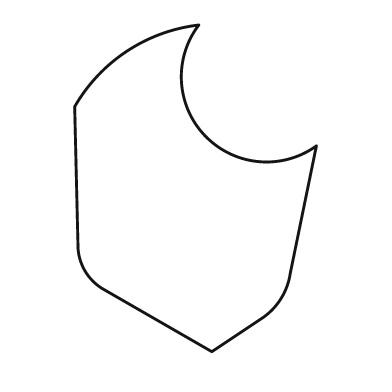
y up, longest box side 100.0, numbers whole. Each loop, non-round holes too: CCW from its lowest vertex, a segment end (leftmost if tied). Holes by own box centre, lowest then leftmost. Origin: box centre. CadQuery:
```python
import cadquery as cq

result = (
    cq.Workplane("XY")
    .moveTo(5.0, -50.0)
    .lineTo(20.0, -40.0)
    .threePointArc((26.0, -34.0), (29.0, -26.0))
    .lineTo(37.0, 13.0)
    .threePointArc((3.0, 16.0), (1.0, 50.0))
    .threePointArc((-21.0, 42.0), (-37.0, 25.0))
    .lineTo(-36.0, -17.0)
    .threePointArc((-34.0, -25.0), (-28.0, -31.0))
    .close()
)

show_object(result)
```